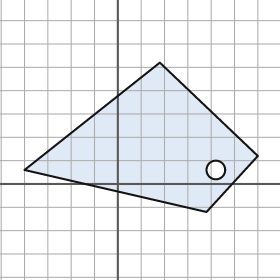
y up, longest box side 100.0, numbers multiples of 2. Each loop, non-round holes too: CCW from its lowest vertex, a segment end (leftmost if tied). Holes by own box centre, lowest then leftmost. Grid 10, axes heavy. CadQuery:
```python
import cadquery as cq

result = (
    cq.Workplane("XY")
    .moveTo(38.0, -12.0)
    .lineTo(60.0, 12.0)
    .lineTo(18.0, 52.0)
    .lineTo(-40.0, 6.0)
    .close()
    .moveTo(42.0, 6.0)
    .circle(4.0)
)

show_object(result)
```